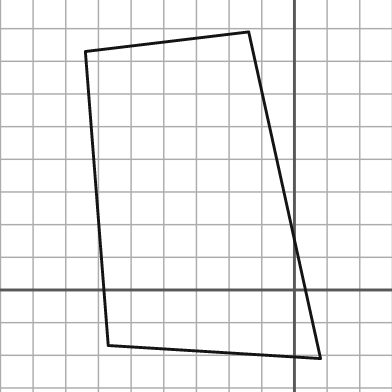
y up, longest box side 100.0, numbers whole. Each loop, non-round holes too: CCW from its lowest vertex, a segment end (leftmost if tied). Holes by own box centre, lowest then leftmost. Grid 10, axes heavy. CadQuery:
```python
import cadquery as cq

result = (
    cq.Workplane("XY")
    .moveTo(8.0, -21.0)
    .lineTo(-14.0, 79.0)
    .lineTo(-64.0, 73.0)
    .lineTo(-57.0, -17.0)
    .close()
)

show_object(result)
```